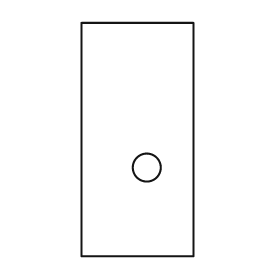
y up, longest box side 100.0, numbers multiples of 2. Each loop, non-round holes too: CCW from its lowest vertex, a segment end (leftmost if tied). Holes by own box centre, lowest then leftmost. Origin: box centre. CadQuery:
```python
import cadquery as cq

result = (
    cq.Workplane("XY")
    .moveTo(-24.0, -50.0)
    .lineTo(24.0, -50.0)
    .lineTo(24.0, 50.0)
    .lineTo(-24.0, 50.0)
    .close()
    .moveTo(4.0, -12.0)
    .circle(6.0)
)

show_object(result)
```